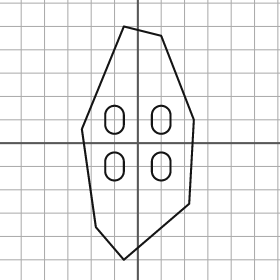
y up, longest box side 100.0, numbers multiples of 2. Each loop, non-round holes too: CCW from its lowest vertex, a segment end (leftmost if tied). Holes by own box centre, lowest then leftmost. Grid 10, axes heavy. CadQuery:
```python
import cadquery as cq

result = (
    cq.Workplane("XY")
    .moveTo(-6.0, -50.0)
    .lineTo(22.0, -26.0)
    .lineTo(24.0, 10.0)
    .lineTo(10.0, 46.0)
    .lineTo(-6.0, 50.0)
    .lineTo(-24.0, 6.0)
    .lineTo(-18.0, -36.0)
    .close()
    .moveTo(-14.0, -12.0)
    .threePointArc((-10.0, -16.0), (-6.0, -12.0))
    .lineTo(-6.0, -8.0)
    .threePointArc((-10.0, -4.0), (-14.0, -8.0))
    .close()
    .moveTo(6.0, -12.0)
    .threePointArc((10.0, -16.0), (14.0, -12.0))
    .lineTo(14.0, -8.0)
    .threePointArc((10.0, -4.0), (6.0, -8.0))
    .close()
    .moveTo(-14.0, 8.0)
    .threePointArc((-10.0, 4.0), (-6.0, 8.0))
    .lineTo(-6.0, 12.0)
    .threePointArc((-10.0, 16.0), (-14.0, 12.0))
    .close()
    .moveTo(6.0, 8.0)
    .threePointArc((10.0, 4.0), (14.0, 8.0))
    .lineTo(14.0, 12.0)
    .threePointArc((10.0, 16.0), (6.0, 12.0))
    .close()
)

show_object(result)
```